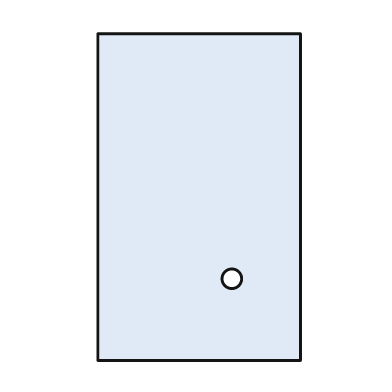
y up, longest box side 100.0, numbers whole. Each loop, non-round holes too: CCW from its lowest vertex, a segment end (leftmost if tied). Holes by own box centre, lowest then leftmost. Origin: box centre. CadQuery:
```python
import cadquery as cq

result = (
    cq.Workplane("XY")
    .moveTo(-31.0, -50.0)
    .lineTo(31.0, -50.0)
    .lineTo(31.0, 50.0)
    .lineTo(-31.0, 50.0)
    .close()
    .moveTo(10.0, -25.0)
    .circle(3.0)
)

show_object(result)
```